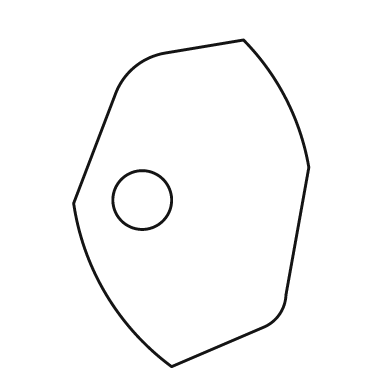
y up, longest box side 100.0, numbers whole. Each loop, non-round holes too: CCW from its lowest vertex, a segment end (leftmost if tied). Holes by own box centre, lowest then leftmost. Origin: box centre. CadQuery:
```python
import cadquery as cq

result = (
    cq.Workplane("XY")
    .moveTo(-6.0, -50.0)
    .lineTo(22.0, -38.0)
    .threePointArc((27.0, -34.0), (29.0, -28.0))
    .lineTo(36.0, 11.0)
    .threePointArc((29.0, 32.0), (16.0, 50.0))
    .lineTo(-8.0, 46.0)
    .threePointArc((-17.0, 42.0), (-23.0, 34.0))
    .lineTo(-36.0, 0.0)
    .threePointArc((-26.0, -28.0), (-6.0, -50.0))
    .close()
    .moveTo(-15.0, 1.0)
    .circle(9.0)
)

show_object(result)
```